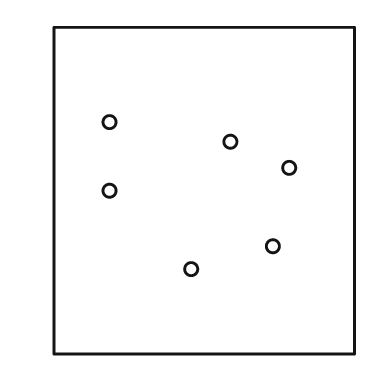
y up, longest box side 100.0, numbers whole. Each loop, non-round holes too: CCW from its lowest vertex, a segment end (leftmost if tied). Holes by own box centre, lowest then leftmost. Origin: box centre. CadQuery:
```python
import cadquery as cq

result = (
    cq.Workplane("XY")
    .moveTo(-46.0, -50.0)
    .lineTo(46.0, -50.0)
    .lineTo(46.0, 50.0)
    .lineTo(-46.0, 50.0)
    .close()
    .moveTo(-4.0, -24.0)
    .circle(2.0)
    .moveTo(21.0, -17.0)
    .circle(2.0)
    .moveTo(-29.0, 0.0)
    .circle(2.0)
    .moveTo(26.0, 7.0)
    .circle(2.0)
    .moveTo(8.0, 15.0)
    .circle(2.0)
    .moveTo(-29.0, 21.0)
    .circle(2.0)
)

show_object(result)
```